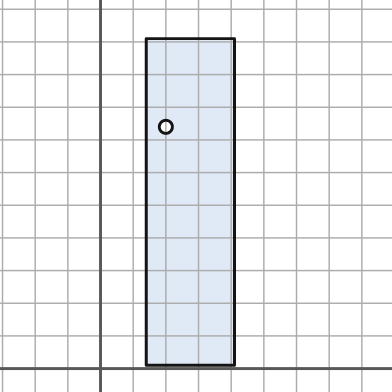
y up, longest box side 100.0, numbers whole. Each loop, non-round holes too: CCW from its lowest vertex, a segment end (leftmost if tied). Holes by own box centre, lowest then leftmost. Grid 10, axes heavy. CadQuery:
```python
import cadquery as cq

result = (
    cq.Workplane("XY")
    .moveTo(14.0, 1.0)
    .lineTo(41.0, 1.0)
    .lineTo(41.0, 101.0)
    .lineTo(14.0, 101.0)
    .close()
    .moveTo(20.0, 74.0)
    .circle(2.0)
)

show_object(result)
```